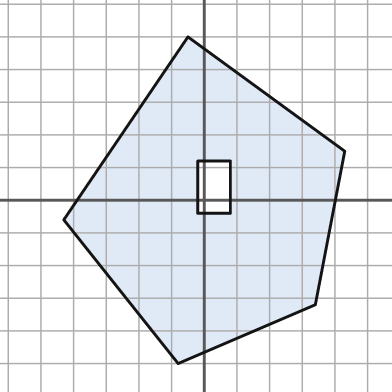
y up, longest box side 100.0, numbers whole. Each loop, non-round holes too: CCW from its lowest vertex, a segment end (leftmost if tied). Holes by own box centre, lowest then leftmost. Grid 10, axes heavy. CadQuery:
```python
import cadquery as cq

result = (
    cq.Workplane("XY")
    .moveTo(-8.0, -50.0)
    .lineTo(34.0, -32.0)
    .lineTo(43.0, 15.0)
    .lineTo(-5.0, 50.0)
    .lineTo(-43.0, -6.0)
    .close()
    .moveTo(-2.0, -4.0)
    .lineTo(8.0, -4.0)
    .lineTo(8.0, 12.0)
    .lineTo(-2.0, 12.0)
    .close()
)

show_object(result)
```